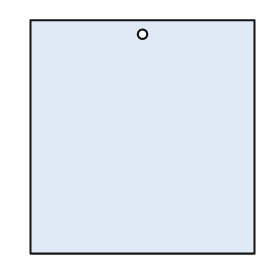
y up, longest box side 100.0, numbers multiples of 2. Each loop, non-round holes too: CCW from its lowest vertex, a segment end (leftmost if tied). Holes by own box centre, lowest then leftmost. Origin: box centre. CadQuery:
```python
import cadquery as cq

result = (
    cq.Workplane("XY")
    .moveTo(-48.0, -50.0)
    .lineTo(48.0, -50.0)
    .lineTo(48.0, 50.0)
    .lineTo(-48.0, 50.0)
    .close()
    .moveTo(0.0, 44.0)
    .circle(2.0)
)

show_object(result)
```